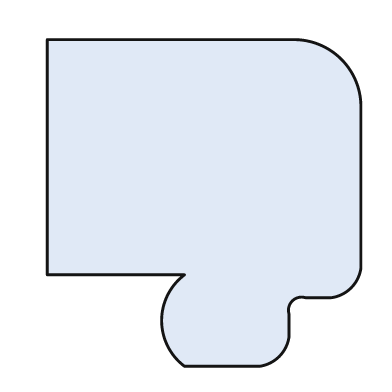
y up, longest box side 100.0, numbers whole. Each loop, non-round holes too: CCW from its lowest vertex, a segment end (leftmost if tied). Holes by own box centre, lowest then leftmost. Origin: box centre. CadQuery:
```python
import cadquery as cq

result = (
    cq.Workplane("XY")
    .moveTo(-6.0, -50.0)
    .lineTo(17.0, -50.0)
    .threePointArc((23.0, -47.0), (26.0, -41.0))
    .lineTo(26.0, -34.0)
    .threePointArc((27.0, -30.0), (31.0, -29.0))
    .lineTo(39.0, -29.0)
    .threePointArc((45.0, -26.0), (48.0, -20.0))
    .lineTo(48.0, 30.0)
    .threePointArc((42.0, 44.0), (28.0, 50.0))
    .lineTo(-48.0, 50.0)
    .lineTo(-48.0, -22.0)
    .lineTo(-6.0, -22.0)
    .threePointArc((-13.0, -36.0), (-6.0, -50.0))
    .close()
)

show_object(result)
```